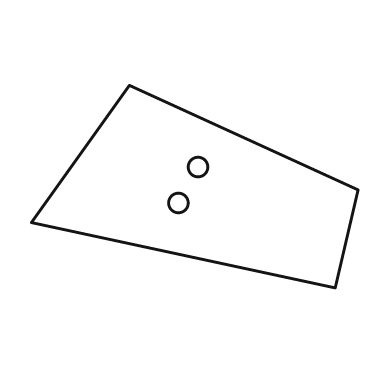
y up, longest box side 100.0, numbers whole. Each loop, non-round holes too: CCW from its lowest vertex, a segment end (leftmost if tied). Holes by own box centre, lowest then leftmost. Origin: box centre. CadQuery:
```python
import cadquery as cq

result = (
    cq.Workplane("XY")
    .moveTo(43.0, -31.0)
    .lineTo(50.0, -1.0)
    .lineTo(-20.0, 31.0)
    .lineTo(-50.0, -11.0)
    .close()
    .moveTo(-5.0, -5.0)
    .circle(3.0)
    .moveTo(1.0, 6.0)
    .circle(3.0)
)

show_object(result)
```